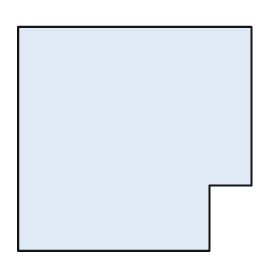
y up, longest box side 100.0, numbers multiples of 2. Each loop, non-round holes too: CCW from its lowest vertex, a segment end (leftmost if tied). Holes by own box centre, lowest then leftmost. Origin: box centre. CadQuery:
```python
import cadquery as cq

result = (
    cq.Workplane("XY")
    .moveTo(-50.0, -48.0)
    .lineTo(32.0, -48.0)
    .lineTo(32.0, -20.0)
    .lineTo(50.0, -20.0)
    .lineTo(50.0, 48.0)
    .lineTo(-50.0, 48.0)
    .close()
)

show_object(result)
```